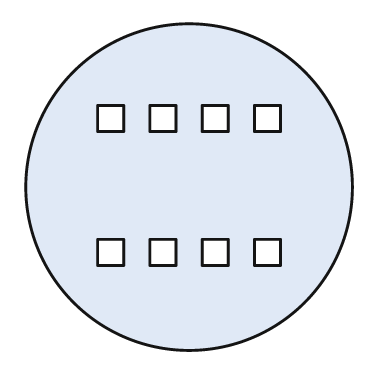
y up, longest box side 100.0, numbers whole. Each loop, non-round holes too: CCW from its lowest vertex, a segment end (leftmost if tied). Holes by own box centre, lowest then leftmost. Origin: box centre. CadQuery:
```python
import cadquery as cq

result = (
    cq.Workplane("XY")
    .moveTo(0.0, 0.0)
    .circle(50.0)
    .moveTo(-28.0, -24.0)
    .lineTo(-20.0, -24.0)
    .lineTo(-20.0, -16.0)
    .lineTo(-28.0, -16.0)
    .close()
    .moveTo(-12.0, -24.0)
    .lineTo(-4.0, -24.0)
    .lineTo(-4.0, -16.0)
    .lineTo(-12.0, -16.0)
    .close()
    .moveTo(4.0, -24.0)
    .lineTo(12.0, -24.0)
    .lineTo(12.0, -16.0)
    .lineTo(4.0, -16.0)
    .close()
    .moveTo(20.0, -24.0)
    .lineTo(28.0, -24.0)
    .lineTo(28.0, -16.0)
    .lineTo(20.0, -16.0)
    .close()
    .moveTo(-28.0, 17.0)
    .lineTo(-20.0, 17.0)
    .lineTo(-20.0, 25.0)
    .lineTo(-28.0, 25.0)
    .close()
    .moveTo(-12.0, 17.0)
    .lineTo(-4.0, 17.0)
    .lineTo(-4.0, 25.0)
    .lineTo(-12.0, 25.0)
    .close()
    .moveTo(4.0, 17.0)
    .lineTo(12.0, 17.0)
    .lineTo(12.0, 25.0)
    .lineTo(4.0, 25.0)
    .close()
    .moveTo(20.0, 17.0)
    .lineTo(28.0, 17.0)
    .lineTo(28.0, 25.0)
    .lineTo(20.0, 25.0)
    .close()
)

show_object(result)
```